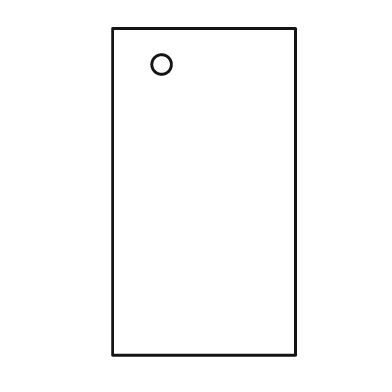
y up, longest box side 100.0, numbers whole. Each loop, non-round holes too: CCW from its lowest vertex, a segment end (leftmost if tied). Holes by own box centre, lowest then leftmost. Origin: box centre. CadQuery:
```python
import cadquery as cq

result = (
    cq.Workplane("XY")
    .moveTo(-28.0, -50.0)
    .lineTo(28.0, -50.0)
    .lineTo(28.0, 50.0)
    .lineTo(-28.0, 50.0)
    .close()
    .moveTo(-13.0, 39.0)
    .circle(3.0)
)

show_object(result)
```